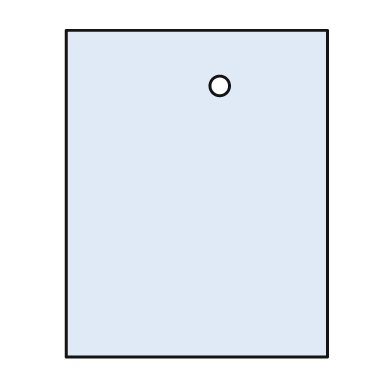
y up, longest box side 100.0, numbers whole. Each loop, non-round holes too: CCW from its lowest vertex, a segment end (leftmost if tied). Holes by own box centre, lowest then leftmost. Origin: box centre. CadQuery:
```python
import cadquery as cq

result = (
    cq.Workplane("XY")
    .moveTo(-40.0, -50.0)
    .lineTo(40.0, -50.0)
    .lineTo(40.0, 50.0)
    .lineTo(-40.0, 50.0)
    .close()
    .moveTo(7.0, 33.0)
    .circle(3.0)
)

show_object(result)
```